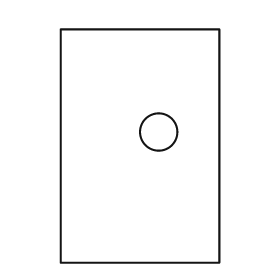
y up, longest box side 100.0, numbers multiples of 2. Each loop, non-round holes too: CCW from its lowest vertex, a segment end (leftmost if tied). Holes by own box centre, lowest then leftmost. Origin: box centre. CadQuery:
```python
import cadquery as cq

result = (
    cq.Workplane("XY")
    .moveTo(-34.0, -50.0)
    .lineTo(34.0, -50.0)
    .lineTo(34.0, 50.0)
    .lineTo(-34.0, 50.0)
    .close()
    .moveTo(8.0, 6.0)
    .circle(8.0)
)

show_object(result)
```